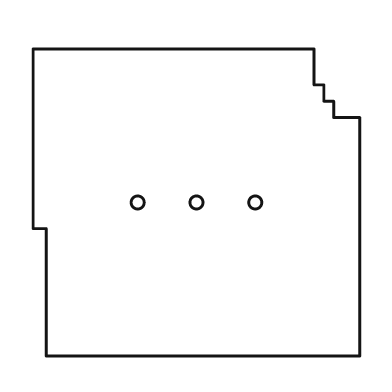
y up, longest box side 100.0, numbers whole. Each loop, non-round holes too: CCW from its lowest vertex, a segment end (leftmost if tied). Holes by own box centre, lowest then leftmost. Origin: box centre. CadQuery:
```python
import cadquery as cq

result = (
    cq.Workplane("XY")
    .moveTo(-46.0, -47.0)
    .lineTo(50.0, -47.0)
    .lineTo(50.0, 26.0)
    .lineTo(42.0, 26.0)
    .lineTo(42.0, 31.0)
    .lineTo(39.0, 31.0)
    .lineTo(39.0, 36.0)
    .lineTo(36.0, 36.0)
    .lineTo(36.0, 47.0)
    .lineTo(-50.0, 47.0)
    .lineTo(-50.0, -8.0)
    .lineTo(-46.0, -8.0)
    .close()
    .moveTo(-18.0, 0.0)
    .circle(2.0)
    .moveTo(0.0, 0.0)
    .circle(2.0)
    .moveTo(18.0, 0.0)
    .circle(2.0)
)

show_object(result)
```